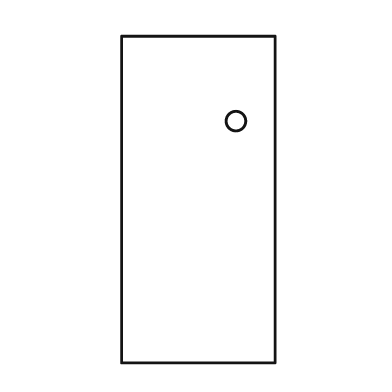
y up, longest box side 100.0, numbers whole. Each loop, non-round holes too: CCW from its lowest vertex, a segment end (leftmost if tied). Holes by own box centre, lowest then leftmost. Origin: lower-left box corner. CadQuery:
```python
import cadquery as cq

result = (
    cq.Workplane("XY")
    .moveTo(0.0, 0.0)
    .lineTo(47.0, 0.0)
    .lineTo(47.0, 100.0)
    .lineTo(0.0, 100.0)
    .close()
    .moveTo(35.0, 74.0)
    .circle(3.0)
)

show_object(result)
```